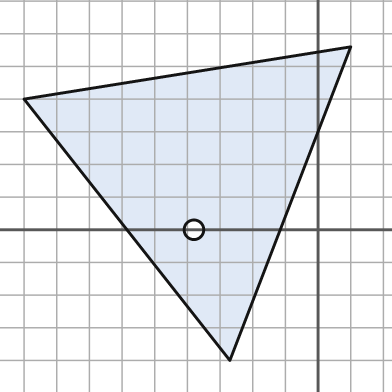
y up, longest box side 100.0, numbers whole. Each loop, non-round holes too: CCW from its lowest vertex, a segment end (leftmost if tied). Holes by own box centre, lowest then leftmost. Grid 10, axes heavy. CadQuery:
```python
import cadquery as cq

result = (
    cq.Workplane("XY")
    .moveTo(-27.0, -40.0)
    .lineTo(10.0, 56.0)
    .lineTo(-90.0, 40.0)
    .close()
    .moveTo(-38.0, 0.0)
    .circle(3.0)
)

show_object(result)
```